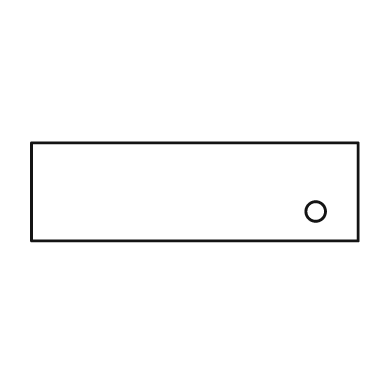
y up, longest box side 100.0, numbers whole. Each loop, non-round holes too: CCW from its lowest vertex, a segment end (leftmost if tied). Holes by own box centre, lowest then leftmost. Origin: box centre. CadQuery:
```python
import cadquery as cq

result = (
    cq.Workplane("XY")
    .moveTo(-50.0, -15.0)
    .lineTo(50.0, -15.0)
    .lineTo(50.0, 15.0)
    .lineTo(-50.0, 15.0)
    .close()
    .moveTo(37.0, -6.0)
    .circle(3.0)
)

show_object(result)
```